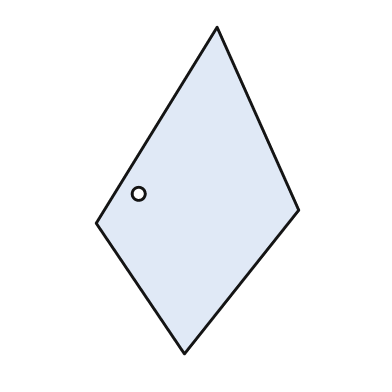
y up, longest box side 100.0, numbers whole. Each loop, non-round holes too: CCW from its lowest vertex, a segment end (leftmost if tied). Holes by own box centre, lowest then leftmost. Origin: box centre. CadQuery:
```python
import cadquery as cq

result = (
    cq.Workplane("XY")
    .moveTo(-4.0, -50.0)
    .lineTo(31.0, -6.0)
    .lineTo(6.0, 50.0)
    .lineTo(-31.0, -10.0)
    .close()
    .moveTo(-18.0, -1.0)
    .circle(2.0)
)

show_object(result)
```